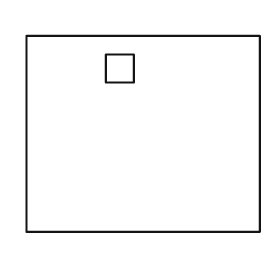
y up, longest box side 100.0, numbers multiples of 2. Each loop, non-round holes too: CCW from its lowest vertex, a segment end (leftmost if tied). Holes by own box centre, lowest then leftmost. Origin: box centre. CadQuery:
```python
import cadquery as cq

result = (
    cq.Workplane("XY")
    .moveTo(-50.0, -42.0)
    .lineTo(50.0, -42.0)
    .lineTo(50.0, 42.0)
    .lineTo(-50.0, 42.0)
    .close()
    .moveTo(-16.0, 22.0)
    .lineTo(-4.0, 22.0)
    .lineTo(-4.0, 34.0)
    .lineTo(-16.0, 34.0)
    .close()
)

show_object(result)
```